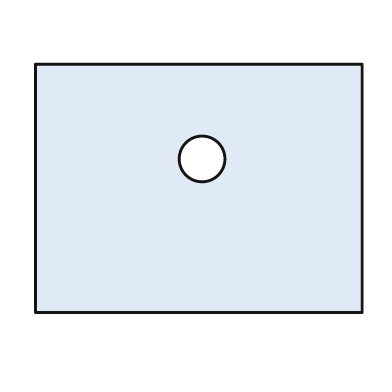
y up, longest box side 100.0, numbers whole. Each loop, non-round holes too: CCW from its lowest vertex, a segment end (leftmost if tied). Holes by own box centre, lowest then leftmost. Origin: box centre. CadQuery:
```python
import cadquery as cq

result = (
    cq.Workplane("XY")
    .moveTo(-50.0, -38.0)
    .lineTo(50.0, -38.0)
    .lineTo(50.0, 38.0)
    .lineTo(-50.0, 38.0)
    .close()
    .moveTo(1.0, 9.0)
    .circle(7.0)
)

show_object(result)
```